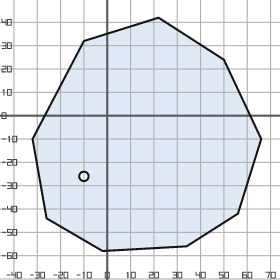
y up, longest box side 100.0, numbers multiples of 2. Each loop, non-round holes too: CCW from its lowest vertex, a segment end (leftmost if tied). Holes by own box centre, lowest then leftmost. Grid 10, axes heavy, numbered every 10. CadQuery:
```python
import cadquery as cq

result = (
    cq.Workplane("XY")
    .moveTo(-2.0, -58.0)
    .lineTo(34.0, -56.0)
    .lineTo(56.0, -42.0)
    .lineTo(66.0, -10.0)
    .lineTo(50.0, 24.0)
    .lineTo(22.0, 42.0)
    .lineTo(-10.0, 32.0)
    .lineTo(-32.0, -10.0)
    .lineTo(-26.0, -44.0)
    .close()
    .moveTo(-10.0, -26.0)
    .circle(2.0)
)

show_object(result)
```